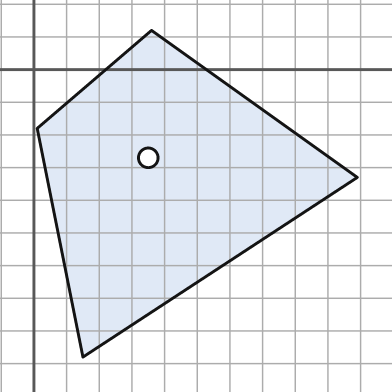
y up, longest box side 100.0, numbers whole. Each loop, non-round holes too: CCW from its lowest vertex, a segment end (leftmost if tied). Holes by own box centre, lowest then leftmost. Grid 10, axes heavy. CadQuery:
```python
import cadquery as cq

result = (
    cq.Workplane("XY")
    .moveTo(15.0, -88.0)
    .lineTo(99.0, -33.0)
    .lineTo(36.0, 12.0)
    .lineTo(1.0, -18.0)
    .close()
    .moveTo(35.0, -27.0)
    .circle(3.0)
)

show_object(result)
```